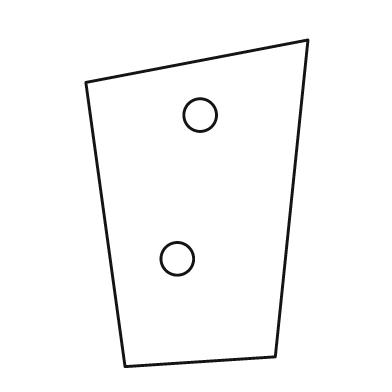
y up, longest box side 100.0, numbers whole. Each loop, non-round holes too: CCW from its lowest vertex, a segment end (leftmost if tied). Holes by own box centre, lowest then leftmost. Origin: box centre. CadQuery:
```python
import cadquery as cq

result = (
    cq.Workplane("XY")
    .moveTo(-22.0, -50.0)
    .lineTo(24.0, -47.0)
    .lineTo(34.0, 50.0)
    .lineTo(-34.0, 37.0)
    .close()
    .moveTo(-6.0, -17.0)
    .circle(5.0)
    .moveTo(1.0, 27.0)
    .circle(5.0)
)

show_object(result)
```